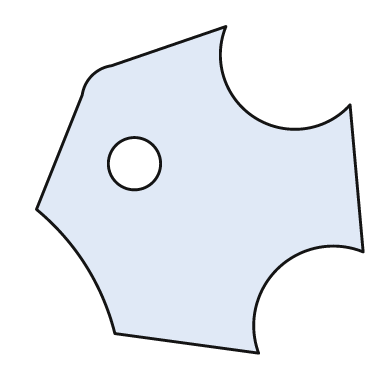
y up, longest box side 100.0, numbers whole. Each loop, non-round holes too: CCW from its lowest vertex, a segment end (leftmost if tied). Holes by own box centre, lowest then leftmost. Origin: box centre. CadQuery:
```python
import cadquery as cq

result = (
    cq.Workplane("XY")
    .moveTo(18.0, -50.0)
    .threePointArc((24.0, -24.0), (50.0, -19.0))
    .lineTo(46.0, 26.0)
    .threePointArc((17.0, 22.0), (8.0, 50.0))
    .lineTo(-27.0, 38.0)
    .threePointArc((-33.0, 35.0), (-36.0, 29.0))
    .lineTo(-50.0, -6.0)
    .threePointArc((-35.0, -23.0), (-26.0, -44.0))
    .close()
    .moveTo(-20.0, 8.0)
    .circle(8.0)
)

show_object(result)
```